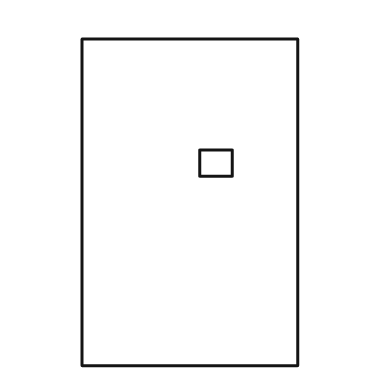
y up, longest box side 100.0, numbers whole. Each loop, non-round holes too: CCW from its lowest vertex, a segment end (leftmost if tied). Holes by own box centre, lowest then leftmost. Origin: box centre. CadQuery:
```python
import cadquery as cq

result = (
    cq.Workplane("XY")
    .moveTo(-33.0, -50.0)
    .lineTo(33.0, -50.0)
    .lineTo(33.0, 50.0)
    .lineTo(-33.0, 50.0)
    .close()
    .moveTo(3.0, 8.0)
    .lineTo(13.0, 8.0)
    .lineTo(13.0, 16.0)
    .lineTo(3.0, 16.0)
    .close()
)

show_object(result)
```